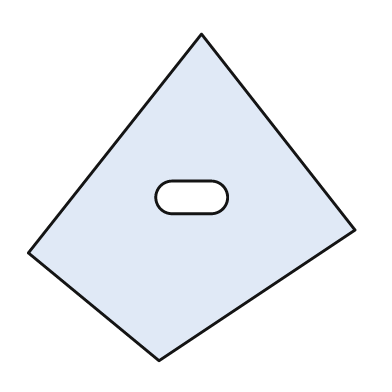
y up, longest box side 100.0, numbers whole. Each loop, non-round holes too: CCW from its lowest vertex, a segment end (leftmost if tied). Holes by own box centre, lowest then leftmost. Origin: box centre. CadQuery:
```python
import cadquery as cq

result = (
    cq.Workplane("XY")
    .moveTo(-10.0, -50.0)
    .lineTo(50.0, -10.0)
    .lineTo(3.0, 50.0)
    .lineTo(-50.0, -17.0)
    .close()
    .moveTo(-6.0, -5.0)
    .lineTo(6.0, -5.0)
    .threePointArc((11.0, 0.0), (6.0, 5.0))
    .lineTo(-6.0, 5.0)
    .threePointArc((-11.0, 0.0), (-6.0, -5.0))
    .close()
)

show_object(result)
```